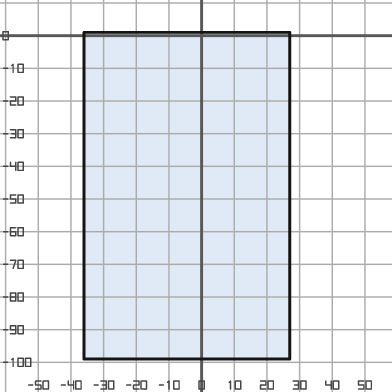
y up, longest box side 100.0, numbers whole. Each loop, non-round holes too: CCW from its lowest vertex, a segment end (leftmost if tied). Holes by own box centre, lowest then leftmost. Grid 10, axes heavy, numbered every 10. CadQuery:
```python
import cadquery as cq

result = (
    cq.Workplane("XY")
    .moveTo(-36.0, -99.0)
    .lineTo(27.0, -99.0)
    .lineTo(27.0, 1.0)
    .lineTo(-36.0, 1.0)
    .close()
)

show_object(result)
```